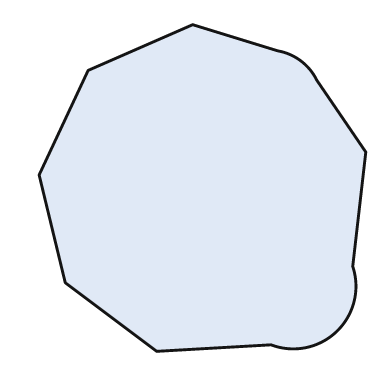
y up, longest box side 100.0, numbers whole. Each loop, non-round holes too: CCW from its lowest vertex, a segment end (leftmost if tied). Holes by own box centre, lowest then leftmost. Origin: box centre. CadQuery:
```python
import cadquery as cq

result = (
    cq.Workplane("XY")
    .moveTo(-14.0, -50.0)
    .lineTo(21.0, -48.0)
    .threePointArc((41.0, -44.0), (46.0, -24.0))
    .lineTo(50.0, 11.0)
    .lineTo(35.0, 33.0)
    .threePointArc((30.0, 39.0), (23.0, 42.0))
    .lineTo(-3.0, 50.0)
    .lineTo(-35.0, 36.0)
    .lineTo(-50.0, 4.0)
    .lineTo(-42.0, -29.0)
    .close()
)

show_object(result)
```